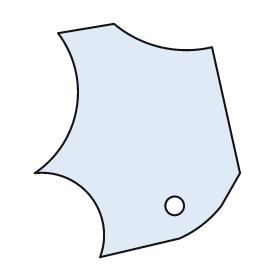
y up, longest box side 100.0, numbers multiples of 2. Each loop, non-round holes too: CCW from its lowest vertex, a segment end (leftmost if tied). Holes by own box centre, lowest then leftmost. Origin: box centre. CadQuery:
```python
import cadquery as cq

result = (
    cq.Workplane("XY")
    .moveTo(-16.0, -50.0)
    .lineTo(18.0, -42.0)
    .threePointArc((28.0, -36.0), (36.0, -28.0))
    .lineTo(44.0, -14.0)
    .lineTo(32.0, 40.0)
    .threePointArc((10.0, 40.0), (-10.0, 50.0))
    .lineTo(-34.0, 46.0)
    .threePointArc((-26.0, 14.0), (-44.0, -14.0))
    .threePointArc((-20.0, -24.0), (-16.0, -50.0))
    .close()
    .moveTo(16.0, -28.0)
    .circle(4.0)
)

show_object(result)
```